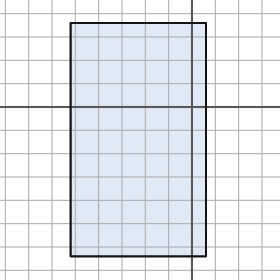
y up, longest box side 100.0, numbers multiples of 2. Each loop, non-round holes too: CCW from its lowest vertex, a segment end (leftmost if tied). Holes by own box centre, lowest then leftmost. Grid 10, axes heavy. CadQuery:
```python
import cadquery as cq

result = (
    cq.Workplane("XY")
    .moveTo(-52.0, -64.0)
    .lineTo(6.0, -64.0)
    .lineTo(6.0, 36.0)
    .lineTo(-52.0, 36.0)
    .close()
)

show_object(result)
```